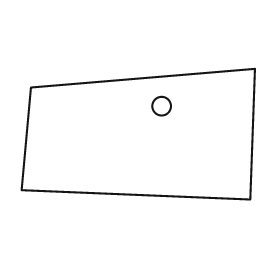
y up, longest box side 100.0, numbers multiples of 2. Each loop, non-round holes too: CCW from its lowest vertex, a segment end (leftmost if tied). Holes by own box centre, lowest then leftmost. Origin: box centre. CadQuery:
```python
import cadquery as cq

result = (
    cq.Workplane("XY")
    .moveTo(48.0, -28.0)
    .lineTo(50.0, 28.0)
    .lineTo(-46.0, 20.0)
    .lineTo(-50.0, -24.0)
    .close()
    .moveTo(10.0, 12.0)
    .circle(4.0)
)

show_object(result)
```